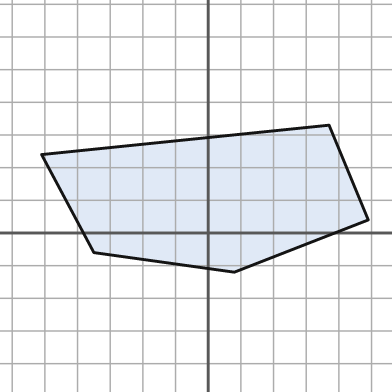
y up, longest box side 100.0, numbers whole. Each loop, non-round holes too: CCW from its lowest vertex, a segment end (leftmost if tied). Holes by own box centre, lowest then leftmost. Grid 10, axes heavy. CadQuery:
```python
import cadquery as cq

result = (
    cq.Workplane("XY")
    .moveTo(8.0, -12.0)
    .lineTo(49.0, 4.0)
    .lineTo(37.0, 33.0)
    .lineTo(-51.0, 24.0)
    .lineTo(-35.0, -6.0)
    .close()
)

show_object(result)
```